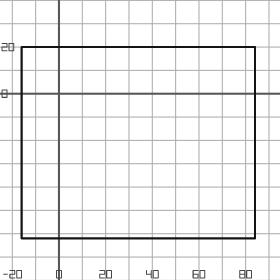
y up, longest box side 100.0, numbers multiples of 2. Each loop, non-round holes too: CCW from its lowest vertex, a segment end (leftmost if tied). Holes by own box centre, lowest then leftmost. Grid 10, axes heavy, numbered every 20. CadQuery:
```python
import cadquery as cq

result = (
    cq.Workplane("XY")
    .moveTo(-16.0, -62.0)
    .lineTo(84.0, -62.0)
    .lineTo(84.0, 20.0)
    .lineTo(-16.0, 20.0)
    .close()
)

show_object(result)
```